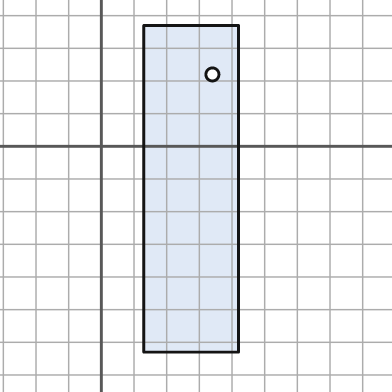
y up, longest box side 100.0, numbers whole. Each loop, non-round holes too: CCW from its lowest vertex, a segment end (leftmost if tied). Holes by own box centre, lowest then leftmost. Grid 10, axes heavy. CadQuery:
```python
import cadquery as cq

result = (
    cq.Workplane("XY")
    .moveTo(13.0, -63.0)
    .lineTo(42.0, -63.0)
    .lineTo(42.0, 37.0)
    .lineTo(13.0, 37.0)
    .close()
    .moveTo(34.0, 22.0)
    .circle(2.0)
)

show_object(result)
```